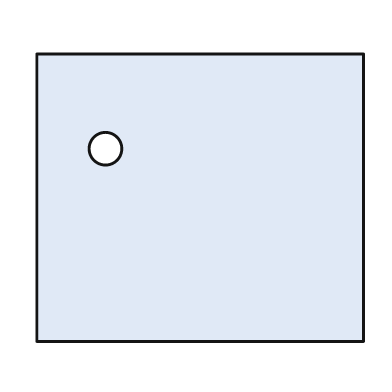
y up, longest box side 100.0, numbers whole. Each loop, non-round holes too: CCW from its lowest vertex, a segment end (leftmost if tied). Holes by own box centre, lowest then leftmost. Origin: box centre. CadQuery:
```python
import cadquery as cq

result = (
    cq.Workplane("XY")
    .moveTo(-50.0, -44.0)
    .lineTo(50.0, -44.0)
    .lineTo(50.0, 44.0)
    .lineTo(-50.0, 44.0)
    .close()
    .moveTo(-29.0, 15.0)
    .circle(5.0)
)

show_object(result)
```